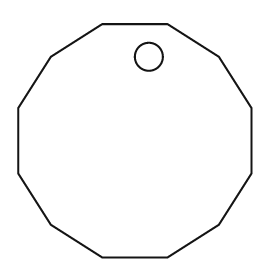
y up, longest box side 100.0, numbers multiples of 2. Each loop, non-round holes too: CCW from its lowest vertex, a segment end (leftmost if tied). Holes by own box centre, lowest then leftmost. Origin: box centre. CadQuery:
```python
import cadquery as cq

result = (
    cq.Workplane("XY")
    .moveTo(-14.0, -50.0)
    .lineTo(14.0, -50.0)
    .lineTo(36.0, -36.0)
    .lineTo(50.0, -14.0)
    .lineTo(50.0, 14.0)
    .lineTo(36.0, 36.0)
    .lineTo(14.0, 50.0)
    .lineTo(-14.0, 50.0)
    .lineTo(-36.0, 36.0)
    .lineTo(-50.0, 14.0)
    .lineTo(-50.0, -14.0)
    .lineTo(-36.0, -36.0)
    .close()
    .moveTo(6.0, 36.0)
    .circle(6.0)
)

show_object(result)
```